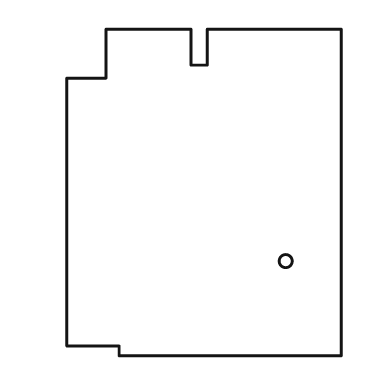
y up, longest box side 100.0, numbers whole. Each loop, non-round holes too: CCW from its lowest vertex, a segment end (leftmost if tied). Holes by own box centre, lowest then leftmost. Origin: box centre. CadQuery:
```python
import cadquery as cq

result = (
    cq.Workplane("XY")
    .moveTo(-26.0, -50.0)
    .lineTo(42.0, -50.0)
    .lineTo(42.0, 50.0)
    .lineTo(1.0, 50.0)
    .lineTo(1.0, 39.0)
    .lineTo(-4.0, 39.0)
    .lineTo(-4.0, 50.0)
    .lineTo(-30.0, 50.0)
    .lineTo(-30.0, 35.0)
    .lineTo(-42.0, 35.0)
    .lineTo(-42.0, -47.0)
    .lineTo(-26.0, -47.0)
    .close()
    .moveTo(25.0, -21.0)
    .circle(2.0)
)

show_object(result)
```